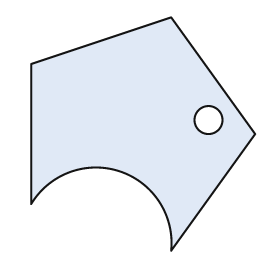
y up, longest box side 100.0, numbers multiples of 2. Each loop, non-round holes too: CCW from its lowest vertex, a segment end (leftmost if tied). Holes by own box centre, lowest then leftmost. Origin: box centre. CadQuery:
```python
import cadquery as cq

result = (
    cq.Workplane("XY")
    .moveTo(12.0, -50.0)
    .lineTo(48.0, 0.0)
    .lineTo(12.0, 50.0)
    .lineTo(-48.0, 30.0)
    .lineTo(-48.0, -30.0)
    .threePointArc((-10.0, -16.0), (12.0, -50.0))
    .close()
    .moveTo(28.0, 6.0)
    .circle(6.0)
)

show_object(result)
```